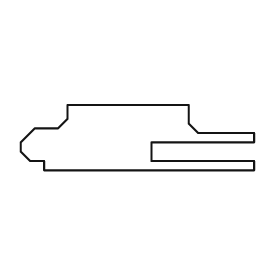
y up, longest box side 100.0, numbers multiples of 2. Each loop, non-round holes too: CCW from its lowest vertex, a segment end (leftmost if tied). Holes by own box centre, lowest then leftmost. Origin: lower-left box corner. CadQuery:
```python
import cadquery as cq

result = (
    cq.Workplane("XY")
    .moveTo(10.0, 0.0)
    .lineTo(100.0, 0.0)
    .lineTo(100.0, 4.0)
    .lineTo(56.0, 4.0)
    .lineTo(56.0, 12.0)
    .lineTo(100.0, 12.0)
    .lineTo(100.0, 16.0)
    .lineTo(76.0, 16.0)
    .lineTo(72.0, 20.0)
    .lineTo(72.0, 28.0)
    .lineTo(20.0, 28.0)
    .lineTo(20.0, 22.0)
    .lineTo(16.0, 18.0)
    .lineTo(6.0, 18.0)
    .lineTo(0.0, 12.0)
    .lineTo(0.0, 8.0)
    .lineTo(4.0, 4.0)
    .lineTo(10.0, 4.0)
    .close()
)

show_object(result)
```